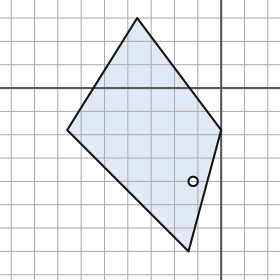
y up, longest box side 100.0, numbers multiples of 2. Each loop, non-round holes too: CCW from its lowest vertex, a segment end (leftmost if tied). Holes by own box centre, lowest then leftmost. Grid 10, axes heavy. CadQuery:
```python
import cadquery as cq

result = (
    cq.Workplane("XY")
    .moveTo(-14.0, -70.0)
    .lineTo(0.0, -18.0)
    .lineTo(-36.0, 30.0)
    .lineTo(-66.0, -18.0)
    .close()
    .moveTo(-12.0, -40.0)
    .circle(2.0)
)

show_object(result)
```